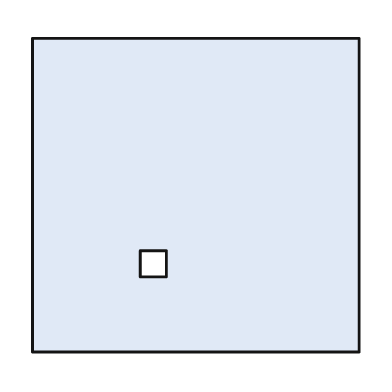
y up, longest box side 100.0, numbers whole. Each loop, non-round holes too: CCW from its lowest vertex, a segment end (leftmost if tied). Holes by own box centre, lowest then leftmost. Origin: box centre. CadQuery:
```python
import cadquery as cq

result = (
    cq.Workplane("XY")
    .moveTo(-50.0, -48.0)
    .lineTo(50.0, -48.0)
    .lineTo(50.0, 48.0)
    .lineTo(-50.0, 48.0)
    .close()
    .moveTo(-17.0, -25.0)
    .lineTo(-9.0, -25.0)
    .lineTo(-9.0, -17.0)
    .lineTo(-17.0, -17.0)
    .close()
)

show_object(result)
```